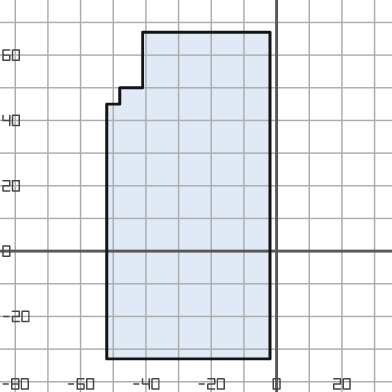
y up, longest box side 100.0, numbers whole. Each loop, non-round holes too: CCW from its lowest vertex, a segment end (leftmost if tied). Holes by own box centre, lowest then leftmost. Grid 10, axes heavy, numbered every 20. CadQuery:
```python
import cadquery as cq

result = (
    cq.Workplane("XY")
    .moveTo(-52.0, -33.0)
    .lineTo(-2.0, -33.0)
    .lineTo(-2.0, 67.0)
    .lineTo(-41.0, 67.0)
    .lineTo(-41.0, 50.0)
    .lineTo(-48.0, 50.0)
    .lineTo(-48.0, 45.0)
    .lineTo(-52.0, 45.0)
    .close()
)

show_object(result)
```